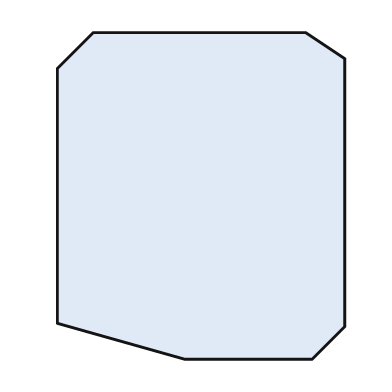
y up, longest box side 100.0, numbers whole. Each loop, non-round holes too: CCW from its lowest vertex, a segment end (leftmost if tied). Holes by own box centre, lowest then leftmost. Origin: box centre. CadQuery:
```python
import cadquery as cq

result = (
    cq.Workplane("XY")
    .moveTo(-5.0, -50.0)
    .lineTo(34.0, -50.0)
    .lineTo(44.0, -40.0)
    .lineTo(44.0, 42.0)
    .lineTo(32.0, 50.0)
    .lineTo(-33.0, 50.0)
    .lineTo(-44.0, 39.0)
    .lineTo(-44.0, -39.0)
    .close()
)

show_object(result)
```